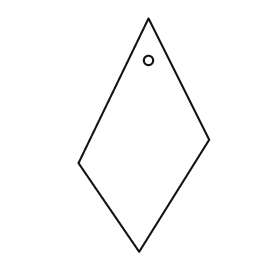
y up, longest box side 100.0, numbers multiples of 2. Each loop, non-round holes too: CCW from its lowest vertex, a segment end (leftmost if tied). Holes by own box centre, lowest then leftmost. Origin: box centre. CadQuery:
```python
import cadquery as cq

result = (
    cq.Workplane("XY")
    .moveTo(-2.0, -50.0)
    .lineTo(28.0, -2.0)
    .lineTo(2.0, 50.0)
    .lineTo(-28.0, -12.0)
    .close()
    .moveTo(2.0, 32.0)
    .circle(2.0)
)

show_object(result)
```